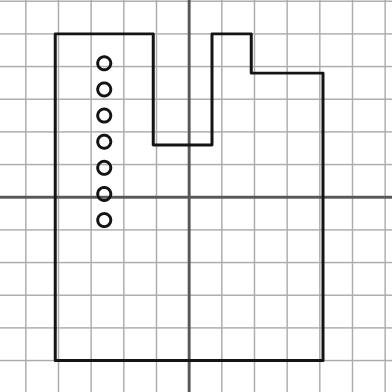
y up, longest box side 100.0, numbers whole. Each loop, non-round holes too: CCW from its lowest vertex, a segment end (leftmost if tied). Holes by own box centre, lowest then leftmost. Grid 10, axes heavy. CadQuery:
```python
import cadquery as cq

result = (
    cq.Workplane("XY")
    .moveTo(-41.0, -50.0)
    .lineTo(41.0, -50.0)
    .lineTo(41.0, 38.0)
    .lineTo(19.0, 38.0)
    .lineTo(19.0, 50.0)
    .lineTo(7.0, 50.0)
    .lineTo(7.0, 16.0)
    .lineTo(-11.0, 16.0)
    .lineTo(-11.0, 50.0)
    .lineTo(-41.0, 50.0)
    .close()
    .moveTo(-26.0, -7.0)
    .circle(2.0)
    .moveTo(-26.0, 1.0)
    .circle(2.0)
    .moveTo(-26.0, 9.0)
    .circle(2.0)
    .moveTo(-26.0, 17.0)
    .circle(2.0)
    .moveTo(-26.0, 25.0)
    .circle(2.0)
    .moveTo(-26.0, 33.0)
    .circle(2.0)
    .moveTo(-26.0, 41.0)
    .circle(2.0)
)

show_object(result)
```